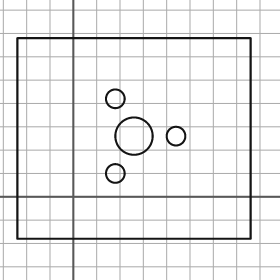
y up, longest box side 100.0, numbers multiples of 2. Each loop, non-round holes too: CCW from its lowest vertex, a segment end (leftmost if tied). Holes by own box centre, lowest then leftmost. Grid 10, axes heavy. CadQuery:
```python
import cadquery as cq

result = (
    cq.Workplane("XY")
    .moveTo(-24.0, -18.0)
    .lineTo(76.0, -18.0)
    .lineTo(76.0, 68.0)
    .lineTo(-24.0, 68.0)
    .close()
    .moveTo(18.0, 10.0)
    .circle(4.0)
    .moveTo(26.0, 26.0)
    .circle(8.0)
    .moveTo(44.0, 26.0)
    .circle(4.0)
    .moveTo(18.0, 42.0)
    .circle(4.0)
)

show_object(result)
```